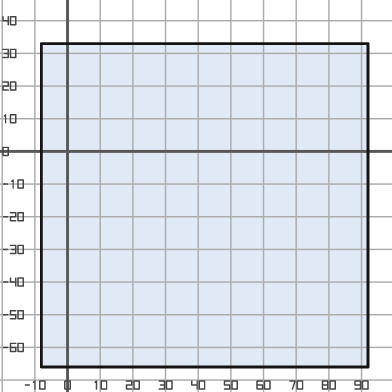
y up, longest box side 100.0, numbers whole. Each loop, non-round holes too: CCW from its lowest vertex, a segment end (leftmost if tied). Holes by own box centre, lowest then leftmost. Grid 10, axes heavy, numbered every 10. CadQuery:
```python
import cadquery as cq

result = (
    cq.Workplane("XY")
    .moveTo(-8.0, -66.0)
    .lineTo(92.0, -66.0)
    .lineTo(92.0, 33.0)
    .lineTo(-8.0, 33.0)
    .close()
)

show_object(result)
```